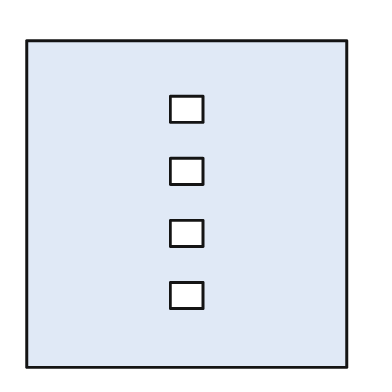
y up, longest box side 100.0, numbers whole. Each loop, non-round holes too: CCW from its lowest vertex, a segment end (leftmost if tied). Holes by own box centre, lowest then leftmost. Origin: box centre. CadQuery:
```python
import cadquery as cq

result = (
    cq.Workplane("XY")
    .moveTo(-49.0, -50.0)
    .lineTo(49.0, -50.0)
    .lineTo(49.0, 50.0)
    .lineTo(-49.0, 50.0)
    .close()
    .moveTo(-5.0, -32.0)
    .lineTo(5.0, -32.0)
    .lineTo(5.0, -24.0)
    .lineTo(-5.0, -24.0)
    .close()
    .moveTo(-5.0, -13.0)
    .lineTo(5.0, -13.0)
    .lineTo(5.0, -5.0)
    .lineTo(-5.0, -5.0)
    .close()
    .moveTo(-5.0, 6.0)
    .lineTo(5.0, 6.0)
    .lineTo(5.0, 14.0)
    .lineTo(-5.0, 14.0)
    .close()
    .moveTo(-5.0, 25.0)
    .lineTo(5.0, 25.0)
    .lineTo(5.0, 33.0)
    .lineTo(-5.0, 33.0)
    .close()
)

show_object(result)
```